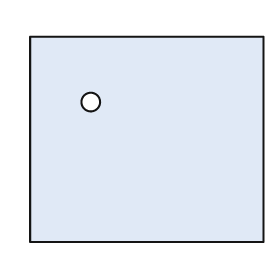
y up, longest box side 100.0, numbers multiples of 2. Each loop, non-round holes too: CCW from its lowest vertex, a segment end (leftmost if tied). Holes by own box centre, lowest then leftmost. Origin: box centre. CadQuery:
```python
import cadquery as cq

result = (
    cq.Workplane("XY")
    .moveTo(-50.0, -44.0)
    .lineTo(50.0, -44.0)
    .lineTo(50.0, 44.0)
    .lineTo(-50.0, 44.0)
    .close()
    .moveTo(-24.0, 16.0)
    .circle(4.0)
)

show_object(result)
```